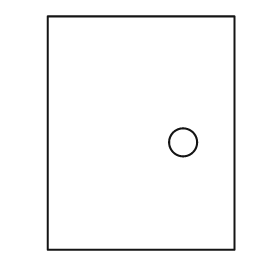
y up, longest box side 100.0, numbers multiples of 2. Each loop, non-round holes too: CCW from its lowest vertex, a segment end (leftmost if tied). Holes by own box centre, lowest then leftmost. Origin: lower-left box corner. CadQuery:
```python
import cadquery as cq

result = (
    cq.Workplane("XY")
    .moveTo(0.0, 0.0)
    .lineTo(80.0, 0.0)
    .lineTo(80.0, 100.0)
    .lineTo(0.0, 100.0)
    .close()
    .moveTo(58.0, 46.0)
    .circle(6.0)
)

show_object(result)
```